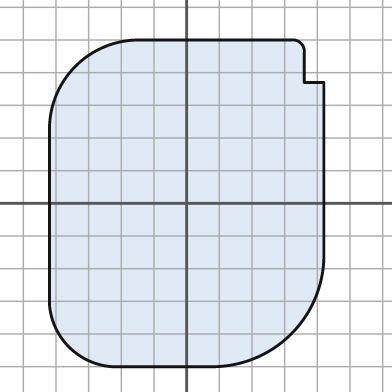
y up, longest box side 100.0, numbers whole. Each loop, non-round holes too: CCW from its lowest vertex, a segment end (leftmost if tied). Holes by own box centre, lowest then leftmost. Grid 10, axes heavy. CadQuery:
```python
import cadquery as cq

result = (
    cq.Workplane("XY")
    .moveTo(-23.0, -50.0)
    .lineTo(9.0, -50.0)
    .threePointArc((32.0, -40.0), (42.0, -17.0))
    .lineTo(42.0, 37.0)
    .lineTo(36.0, 37.0)
    .lineTo(36.0, 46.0)
    .threePointArc((35.0, 49.0), (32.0, 50.0))
    .lineTo(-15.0, 50.0)
    .threePointArc((-34.0, 42.0), (-42.0, 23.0))
    .lineTo(-42.0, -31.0)
    .threePointArc((-36.0, -44.0), (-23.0, -50.0))
    .close()
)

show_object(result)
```